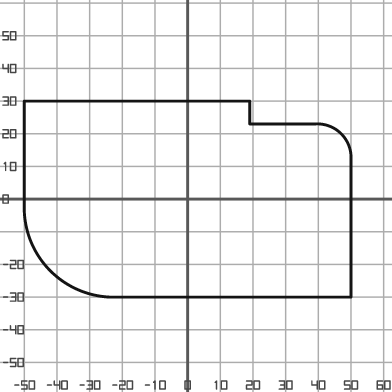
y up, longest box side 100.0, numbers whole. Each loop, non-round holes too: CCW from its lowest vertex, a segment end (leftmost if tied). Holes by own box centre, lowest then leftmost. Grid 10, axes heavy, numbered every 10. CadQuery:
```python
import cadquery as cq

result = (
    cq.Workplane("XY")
    .moveTo(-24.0, -30.0)
    .lineTo(50.0, -30.0)
    .lineTo(50.0, 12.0)
    .threePointArc((47.0, 20.0), (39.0, 23.0))
    .lineTo(19.0, 23.0)
    .lineTo(19.0, 30.0)
    .lineTo(-50.0, 30.0)
    .lineTo(-50.0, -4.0)
    .threePointArc((-42.0, -22.0), (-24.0, -30.0))
    .close()
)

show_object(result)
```